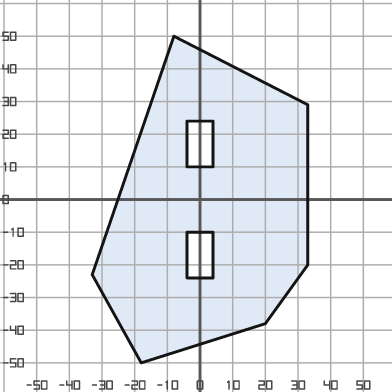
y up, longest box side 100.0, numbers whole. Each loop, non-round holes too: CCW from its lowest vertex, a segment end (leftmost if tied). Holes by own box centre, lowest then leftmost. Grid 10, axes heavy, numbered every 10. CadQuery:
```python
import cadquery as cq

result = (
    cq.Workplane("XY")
    .moveTo(-18.0, -50.0)
    .lineTo(20.0, -38.0)
    .lineTo(33.0, -20.0)
    .lineTo(33.0, 29.0)
    .lineTo(-8.0, 50.0)
    .lineTo(-33.0, -23.0)
    .close()
    .moveTo(-4.0, -24.0)
    .lineTo(4.0, -24.0)
    .lineTo(4.0, -10.0)
    .lineTo(-4.0, -10.0)
    .close()
    .moveTo(-4.0, 10.0)
    .lineTo(4.0, 10.0)
    .lineTo(4.0, 24.0)
    .lineTo(-4.0, 24.0)
    .close()
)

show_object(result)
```